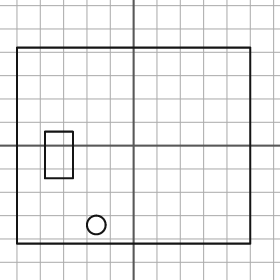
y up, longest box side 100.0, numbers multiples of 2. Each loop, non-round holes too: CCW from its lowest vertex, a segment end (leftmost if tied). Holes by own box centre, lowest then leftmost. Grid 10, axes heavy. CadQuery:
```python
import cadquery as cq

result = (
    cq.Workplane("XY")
    .moveTo(-50.0, -42.0)
    .lineTo(50.0, -42.0)
    .lineTo(50.0, 42.0)
    .lineTo(-50.0, 42.0)
    .close()
    .moveTo(-16.0, -34.0)
    .circle(4.0)
    .moveTo(-38.0, -14.0)
    .lineTo(-26.0, -14.0)
    .lineTo(-26.0, 6.0)
    .lineTo(-38.0, 6.0)
    .close()
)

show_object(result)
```